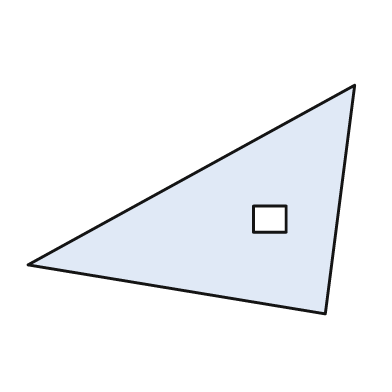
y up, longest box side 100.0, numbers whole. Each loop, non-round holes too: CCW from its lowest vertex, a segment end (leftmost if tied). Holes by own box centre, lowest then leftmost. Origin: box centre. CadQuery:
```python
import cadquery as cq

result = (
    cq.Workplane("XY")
    .moveTo(41.0, -35.0)
    .lineTo(50.0, 35.0)
    .lineTo(-50.0, -20.0)
    .close()
    .moveTo(19.0, -10.0)
    .lineTo(29.0, -10.0)
    .lineTo(29.0, -2.0)
    .lineTo(19.0, -2.0)
    .close()
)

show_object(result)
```